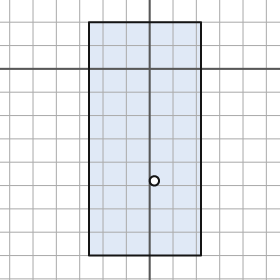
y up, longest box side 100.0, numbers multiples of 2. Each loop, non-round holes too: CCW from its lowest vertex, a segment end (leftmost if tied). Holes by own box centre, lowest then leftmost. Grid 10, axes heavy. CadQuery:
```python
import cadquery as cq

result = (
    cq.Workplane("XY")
    .moveTo(-26.0, -80.0)
    .lineTo(22.0, -80.0)
    .lineTo(22.0, 20.0)
    .lineTo(-26.0, 20.0)
    .close()
    .moveTo(2.0, -48.0)
    .circle(2.0)
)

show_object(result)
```